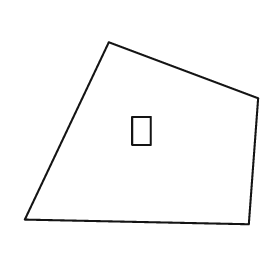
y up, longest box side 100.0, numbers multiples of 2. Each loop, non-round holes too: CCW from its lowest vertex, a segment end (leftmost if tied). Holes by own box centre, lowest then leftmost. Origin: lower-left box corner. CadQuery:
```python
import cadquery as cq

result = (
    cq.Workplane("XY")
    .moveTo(96.0, 0.0)
    .lineTo(100.0, 54.0)
    .lineTo(36.0, 78.0)
    .lineTo(0.0, 2.0)
    .close()
    .moveTo(46.0, 34.0)
    .lineTo(54.0, 34.0)
    .lineTo(54.0, 46.0)
    .lineTo(46.0, 46.0)
    .close()
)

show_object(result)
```